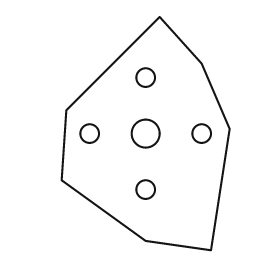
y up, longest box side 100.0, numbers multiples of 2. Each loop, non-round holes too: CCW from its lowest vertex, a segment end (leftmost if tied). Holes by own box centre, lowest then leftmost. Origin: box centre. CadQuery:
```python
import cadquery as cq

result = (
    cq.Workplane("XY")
    .moveTo(28.0, -50.0)
    .lineTo(36.0, 2.0)
    .lineTo(24.0, 30.0)
    .lineTo(6.0, 50.0)
    .lineTo(-34.0, 10.0)
    .lineTo(-36.0, -20.0)
    .lineTo(0.0, -46.0)
    .close()
    .moveTo(0.0, -24.0)
    .circle(4.0)
    .moveTo(-24.0, 0.0)
    .circle(4.0)
    .moveTo(0.0, 0.0)
    .circle(6.0)
    .moveTo(24.0, 0.0)
    .circle(4.0)
    .moveTo(0.0, 24.0)
    .circle(4.0)
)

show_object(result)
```